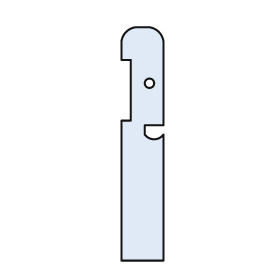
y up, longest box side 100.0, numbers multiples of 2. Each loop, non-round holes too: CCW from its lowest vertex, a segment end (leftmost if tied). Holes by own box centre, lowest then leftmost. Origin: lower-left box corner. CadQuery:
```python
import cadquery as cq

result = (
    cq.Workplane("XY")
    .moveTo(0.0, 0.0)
    .lineTo(18.0, 0.0)
    .lineTo(18.0, 54.0)
    .threePointArc((14.0, 52.0), (10.0, 54.0))
    .lineTo(10.0, 58.0)
    .lineTo(18.0, 58.0)
    .lineTo(18.0, 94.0)
    .threePointArc((16.0, 98.0), (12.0, 100.0))
    .lineTo(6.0, 100.0)
    .threePointArc((2.0, 98.0), (0.0, 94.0))
    .lineTo(0.0, 86.0)
    .lineTo(4.0, 86.0)
    .lineTo(4.0, 60.0)
    .lineTo(0.0, 60.0)
    .close()
    .moveTo(12.0, 76.0)
    .circle(2.0)
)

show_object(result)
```